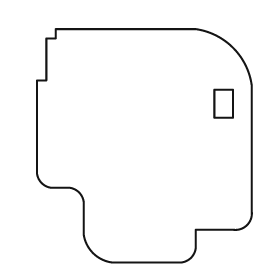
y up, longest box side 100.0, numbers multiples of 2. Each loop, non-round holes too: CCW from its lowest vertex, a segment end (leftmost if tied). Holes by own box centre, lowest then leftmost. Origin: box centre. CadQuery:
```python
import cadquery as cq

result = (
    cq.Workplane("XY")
    .moveTo(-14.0, -50.0)
    .lineTo(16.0, -50.0)
    .threePointArc((20.0, -48.0), (22.0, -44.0))
    .lineTo(22.0, -36.0)
    .lineTo(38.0, -36.0)
    .threePointArc((44.0, -34.0), (46.0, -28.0))
    .lineTo(46.0, 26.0)
    .threePointArc((38.0, 42.0), (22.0, 50.0))
    .lineTo(-38.0, 50.0)
    .lineTo(-38.0, 46.0)
    .lineTo(-42.0, 46.0)
    .lineTo(-42.0, 28.0)
    .lineTo(-46.0, 28.0)
    .lineTo(-46.0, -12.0)
    .threePointArc((-44.0, -16.0), (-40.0, -18.0))
    .lineTo(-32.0, -18.0)
    .threePointArc((-28.0, -20.0), (-26.0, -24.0))
    .lineTo(-26.0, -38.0)
    .threePointArc((-22.0, -46.0), (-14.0, -50.0))
    .close()
    .moveTo(30.0, 12.0)
    .lineTo(38.0, 12.0)
    .lineTo(38.0, 24.0)
    .lineTo(30.0, 24.0)
    .close()
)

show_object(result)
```